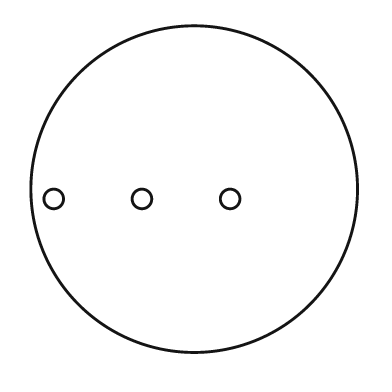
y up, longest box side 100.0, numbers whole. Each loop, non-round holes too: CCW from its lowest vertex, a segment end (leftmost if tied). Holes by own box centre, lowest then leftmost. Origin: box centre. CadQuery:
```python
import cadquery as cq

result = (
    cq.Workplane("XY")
    .moveTo(0.0, 0.0)
    .circle(50.0)
    .moveTo(-43.0, -3.0)
    .circle(3.0)
    .moveTo(-16.0, -3.0)
    .circle(3.0)
    .moveTo(11.0, -3.0)
    .circle(3.0)
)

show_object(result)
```